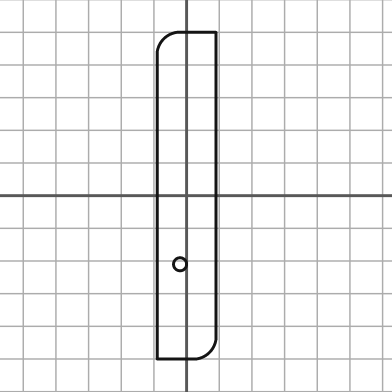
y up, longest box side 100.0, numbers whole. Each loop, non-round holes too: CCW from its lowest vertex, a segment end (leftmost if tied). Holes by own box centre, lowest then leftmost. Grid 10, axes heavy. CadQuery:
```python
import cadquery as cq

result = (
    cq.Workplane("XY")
    .moveTo(-9.0, -50.0)
    .lineTo(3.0, -50.0)
    .threePointArc((7.0, -48.0), (9.0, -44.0))
    .lineTo(9.0, 50.0)
    .lineTo(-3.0, 50.0)
    .threePointArc((-7.0, 48.0), (-9.0, 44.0))
    .close()
    .moveTo(-2.0, -21.0)
    .circle(2.0)
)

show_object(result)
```